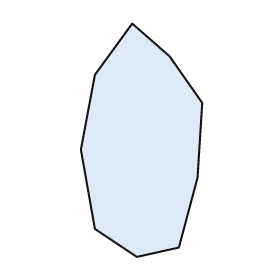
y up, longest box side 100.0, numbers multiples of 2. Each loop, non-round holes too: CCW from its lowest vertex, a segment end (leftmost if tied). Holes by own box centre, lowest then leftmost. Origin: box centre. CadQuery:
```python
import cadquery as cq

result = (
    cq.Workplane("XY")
    .moveTo(-2.0, -50.0)
    .lineTo(16.0, -46.0)
    .lineTo(24.0, -16.0)
    .lineTo(26.0, 16.0)
    .lineTo(12.0, 36.0)
    .lineTo(-4.0, 50.0)
    .lineTo(-20.0, 28.0)
    .lineTo(-26.0, -4.0)
    .lineTo(-20.0, -38.0)
    .close()
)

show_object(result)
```